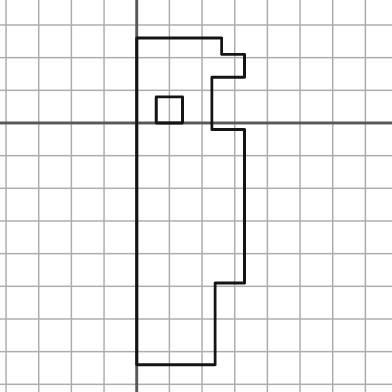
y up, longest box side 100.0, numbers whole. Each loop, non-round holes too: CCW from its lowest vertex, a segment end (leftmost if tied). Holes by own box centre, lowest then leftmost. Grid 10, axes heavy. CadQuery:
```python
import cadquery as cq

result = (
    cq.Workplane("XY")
    .moveTo(0.0, -74.0)
    .lineTo(24.0, -74.0)
    .lineTo(24.0, -49.0)
    .lineTo(33.0, -49.0)
    .lineTo(33.0, -2.0)
    .lineTo(23.0, -2.0)
    .lineTo(23.0, 14.0)
    .lineTo(33.0, 14.0)
    .lineTo(33.0, 21.0)
    .lineTo(26.0, 21.0)
    .lineTo(26.0, 26.0)
    .lineTo(0.0, 26.0)
    .close()
    .moveTo(6.0, 0.0)
    .lineTo(14.0, 0.0)
    .lineTo(14.0, 8.0)
    .lineTo(6.0, 8.0)
    .close()
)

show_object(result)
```